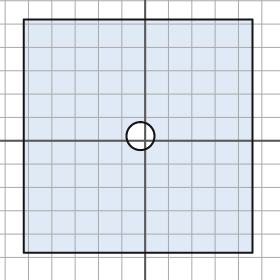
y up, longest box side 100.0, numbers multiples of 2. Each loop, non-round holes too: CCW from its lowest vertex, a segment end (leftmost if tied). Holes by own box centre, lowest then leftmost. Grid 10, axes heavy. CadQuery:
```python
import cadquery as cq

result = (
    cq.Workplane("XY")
    .moveTo(-52.0, -48.0)
    .lineTo(46.0, -48.0)
    .lineTo(46.0, 52.0)
    .lineTo(-52.0, 52.0)
    .close()
    .moveTo(-2.0, 2.0)
    .circle(6.0)
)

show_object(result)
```